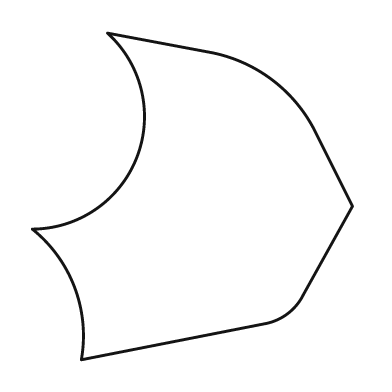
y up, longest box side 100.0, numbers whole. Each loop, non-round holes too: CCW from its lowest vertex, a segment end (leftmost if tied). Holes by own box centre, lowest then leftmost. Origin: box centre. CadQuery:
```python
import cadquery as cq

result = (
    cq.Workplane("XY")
    .moveTo(-34.0, -50.0)
    .lineTo(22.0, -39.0)
    .threePointArc((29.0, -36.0), (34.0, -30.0))
    .lineTo(49.0, -3.0)
    .lineTo(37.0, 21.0)
    .threePointArc((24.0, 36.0), (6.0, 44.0))
    .lineTo(-26.0, 50.0)
    .threePointArc((-17.0, 12.0), (-49.0, -10.0))
    .threePointArc((-36.0, -28.0), (-34.0, -50.0))
    .close()
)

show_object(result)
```